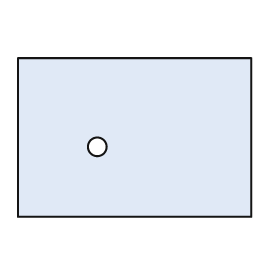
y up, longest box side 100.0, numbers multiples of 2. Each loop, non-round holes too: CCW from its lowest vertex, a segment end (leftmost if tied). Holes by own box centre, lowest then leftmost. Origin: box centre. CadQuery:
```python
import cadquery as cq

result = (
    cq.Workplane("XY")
    .moveTo(-50.0, -34.0)
    .lineTo(50.0, -34.0)
    .lineTo(50.0, 34.0)
    .lineTo(-50.0, 34.0)
    .close()
    .moveTo(-16.0, -4.0)
    .circle(4.0)
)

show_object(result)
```